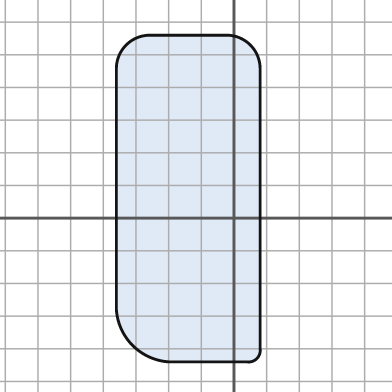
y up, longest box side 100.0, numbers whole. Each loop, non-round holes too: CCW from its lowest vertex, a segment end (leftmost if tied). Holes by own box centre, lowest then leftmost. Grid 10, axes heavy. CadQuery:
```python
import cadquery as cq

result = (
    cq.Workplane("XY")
    .moveTo(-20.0, -44.0)
    .lineTo(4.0, -44.0)
    .threePointArc((7.0, -43.0), (8.0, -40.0))
    .lineTo(8.0, 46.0)
    .threePointArc((5.0, 53.0), (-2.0, 56.0))
    .lineTo(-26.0, 56.0)
    .threePointArc((-33.0, 53.0), (-36.0, 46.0))
    .lineTo(-36.0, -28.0)
    .threePointArc((-31.0, -39.0), (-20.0, -44.0))
    .close()
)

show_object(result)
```